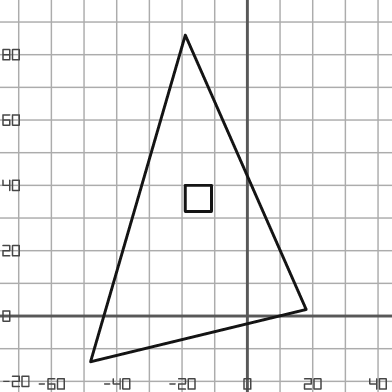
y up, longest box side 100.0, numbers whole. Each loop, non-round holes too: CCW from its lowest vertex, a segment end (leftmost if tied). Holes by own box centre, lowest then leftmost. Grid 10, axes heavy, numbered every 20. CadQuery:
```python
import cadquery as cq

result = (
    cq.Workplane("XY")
    .moveTo(-48.0, -14.0)
    .lineTo(18.0, 2.0)
    .lineTo(-19.0, 86.0)
    .close()
    .moveTo(-19.0, 32.0)
    .lineTo(-11.0, 32.0)
    .lineTo(-11.0, 40.0)
    .lineTo(-19.0, 40.0)
    .close()
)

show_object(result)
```